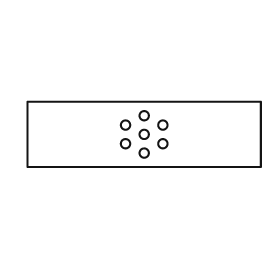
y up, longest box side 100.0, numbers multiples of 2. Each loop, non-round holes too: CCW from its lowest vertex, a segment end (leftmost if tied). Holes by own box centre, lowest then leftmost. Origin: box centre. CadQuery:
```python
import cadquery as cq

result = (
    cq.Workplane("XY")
    .moveTo(-50.0, -14.0)
    .lineTo(50.0, -14.0)
    .lineTo(50.0, 14.0)
    .lineTo(-50.0, 14.0)
    .close()
    .moveTo(0.0, -8.0)
    .circle(2.0)
    .moveTo(-8.0, -4.0)
    .circle(2.0)
    .moveTo(8.0, -4.0)
    .circle(2.0)
    .moveTo(0.0, 0.0)
    .circle(2.0)
    .moveTo(-8.0, 4.0)
    .circle(2.0)
    .moveTo(8.0, 4.0)
    .circle(2.0)
    .moveTo(0.0, 8.0)
    .circle(2.0)
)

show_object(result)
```